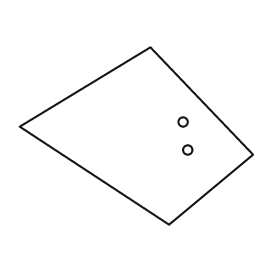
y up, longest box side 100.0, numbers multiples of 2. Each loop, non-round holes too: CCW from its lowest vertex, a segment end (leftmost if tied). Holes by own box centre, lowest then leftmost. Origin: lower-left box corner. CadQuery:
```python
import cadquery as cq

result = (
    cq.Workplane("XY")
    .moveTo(64.0, 0.0)
    .lineTo(100.0, 30.0)
    .lineTo(56.0, 76.0)
    .lineTo(0.0, 42.0)
    .close()
    .moveTo(72.0, 32.0)
    .circle(2.0)
    .moveTo(70.0, 44.0)
    .circle(2.0)
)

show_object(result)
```